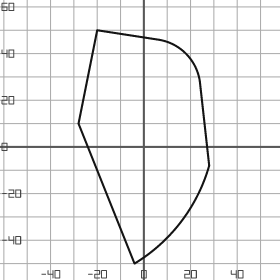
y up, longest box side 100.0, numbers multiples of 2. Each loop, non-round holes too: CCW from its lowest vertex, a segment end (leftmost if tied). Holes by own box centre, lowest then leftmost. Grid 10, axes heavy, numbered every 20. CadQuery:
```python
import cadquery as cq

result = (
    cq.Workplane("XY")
    .moveTo(-4.0, -50.0)
    .threePointArc((16.0, -32.0), (28.0, -8.0))
    .lineTo(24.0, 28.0)
    .threePointArc((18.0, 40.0), (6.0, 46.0))
    .lineTo(-20.0, 50.0)
    .lineTo(-28.0, 10.0)
    .close()
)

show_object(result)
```